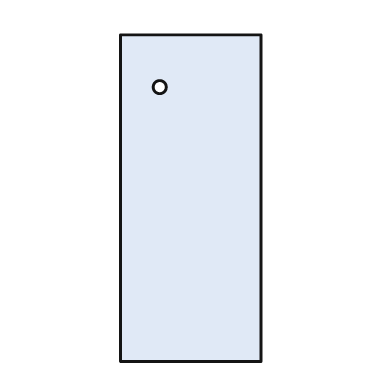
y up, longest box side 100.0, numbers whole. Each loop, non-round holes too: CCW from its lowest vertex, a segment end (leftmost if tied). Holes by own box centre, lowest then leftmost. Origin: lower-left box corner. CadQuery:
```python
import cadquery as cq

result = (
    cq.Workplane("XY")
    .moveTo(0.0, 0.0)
    .lineTo(43.0, 0.0)
    .lineTo(43.0, 100.0)
    .lineTo(0.0, 100.0)
    .close()
    .moveTo(12.0, 84.0)
    .circle(2.0)
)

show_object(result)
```